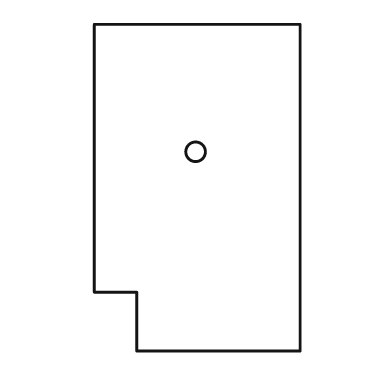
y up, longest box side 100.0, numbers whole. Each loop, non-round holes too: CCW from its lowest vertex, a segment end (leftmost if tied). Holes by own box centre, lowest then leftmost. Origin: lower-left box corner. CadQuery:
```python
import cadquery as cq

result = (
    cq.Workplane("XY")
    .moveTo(13.0, 0.0)
    .lineTo(63.0, 0.0)
    .lineTo(63.0, 100.0)
    .lineTo(0.0, 100.0)
    .lineTo(0.0, 18.0)
    .lineTo(13.0, 18.0)
    .close()
    .moveTo(31.0, 61.0)
    .circle(3.0)
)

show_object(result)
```